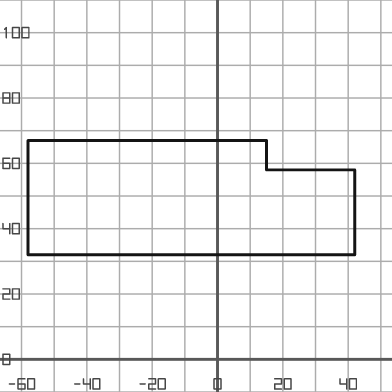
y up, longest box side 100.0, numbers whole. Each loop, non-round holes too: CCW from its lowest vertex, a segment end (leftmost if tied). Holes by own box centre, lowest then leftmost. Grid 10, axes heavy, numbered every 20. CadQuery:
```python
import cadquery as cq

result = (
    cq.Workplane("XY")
    .moveTo(-58.0, 32.0)
    .lineTo(42.0, 32.0)
    .lineTo(42.0, 58.0)
    .lineTo(15.0, 58.0)
    .lineTo(15.0, 67.0)
    .lineTo(-58.0, 67.0)
    .close()
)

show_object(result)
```